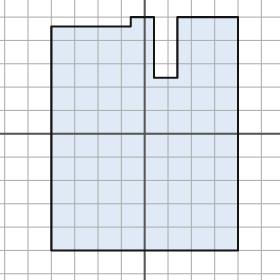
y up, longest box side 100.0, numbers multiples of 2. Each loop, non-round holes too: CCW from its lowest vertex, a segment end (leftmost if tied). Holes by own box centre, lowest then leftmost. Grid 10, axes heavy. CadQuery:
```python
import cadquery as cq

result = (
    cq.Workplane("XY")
    .moveTo(-40.0, -50.0)
    .lineTo(40.0, -50.0)
    .lineTo(40.0, 50.0)
    .lineTo(14.0, 50.0)
    .lineTo(14.0, 24.0)
    .lineTo(4.0, 24.0)
    .lineTo(4.0, 50.0)
    .lineTo(-6.0, 50.0)
    .lineTo(-6.0, 46.0)
    .lineTo(-40.0, 46.0)
    .close()
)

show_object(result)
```